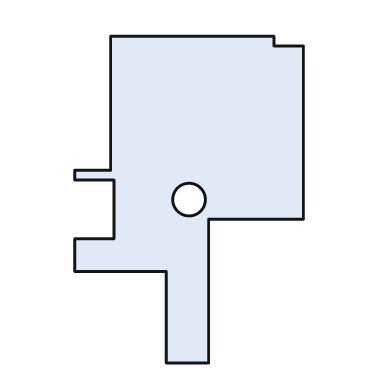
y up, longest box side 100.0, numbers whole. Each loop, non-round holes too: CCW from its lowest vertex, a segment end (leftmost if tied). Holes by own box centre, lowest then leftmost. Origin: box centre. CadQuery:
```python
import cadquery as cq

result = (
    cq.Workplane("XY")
    .moveTo(-7.0, -50.0)
    .lineTo(6.0, -50.0)
    .lineTo(6.0, -6.0)
    .lineTo(35.0, -6.0)
    .lineTo(35.0, 47.0)
    .lineTo(26.0, 47.0)
    .lineTo(26.0, 50.0)
    .lineTo(-24.0, 50.0)
    .lineTo(-24.0, 9.0)
    .lineTo(-35.0, 9.0)
    .lineTo(-35.0, 6.0)
    .lineTo(-23.0, 6.0)
    .lineTo(-23.0, -12.0)
    .lineTo(-35.0, -12.0)
    .lineTo(-35.0, -22.0)
    .lineTo(-7.0, -22.0)
    .close()
    .moveTo(0.0, 0.0)
    .circle(5.0)
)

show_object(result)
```